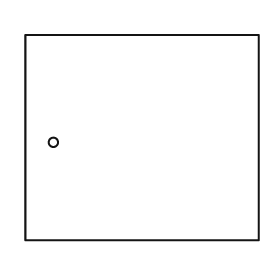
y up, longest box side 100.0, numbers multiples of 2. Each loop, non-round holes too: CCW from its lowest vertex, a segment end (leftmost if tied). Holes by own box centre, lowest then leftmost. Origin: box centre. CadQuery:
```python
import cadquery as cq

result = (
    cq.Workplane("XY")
    .moveTo(-50.0, -44.0)
    .lineTo(50.0, -44.0)
    .lineTo(50.0, 44.0)
    .lineTo(-50.0, 44.0)
    .close()
    .moveTo(-38.0, -2.0)
    .circle(2.0)
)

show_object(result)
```